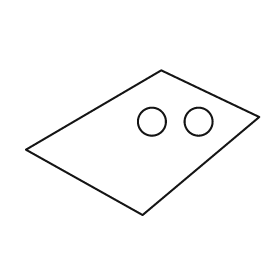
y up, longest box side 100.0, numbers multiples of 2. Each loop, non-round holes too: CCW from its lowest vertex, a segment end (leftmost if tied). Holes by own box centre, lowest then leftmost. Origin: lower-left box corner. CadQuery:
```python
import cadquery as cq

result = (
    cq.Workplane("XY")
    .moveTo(50.0, 0.0)
    .lineTo(100.0, 42.0)
    .lineTo(58.0, 62.0)
    .lineTo(0.0, 28.0)
    .close()
    .moveTo(54.0, 40.0)
    .circle(6.0)
    .moveTo(74.0, 40.0)
    .circle(6.0)
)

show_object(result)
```